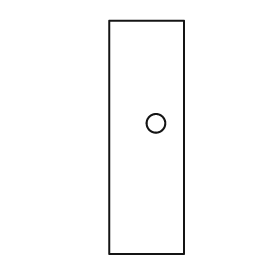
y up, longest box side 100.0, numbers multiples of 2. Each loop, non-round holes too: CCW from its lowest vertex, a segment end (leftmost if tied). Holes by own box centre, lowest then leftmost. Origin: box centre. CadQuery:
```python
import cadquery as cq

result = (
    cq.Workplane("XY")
    .moveTo(-16.0, -50.0)
    .lineTo(16.0, -50.0)
    .lineTo(16.0, 50.0)
    .lineTo(-16.0, 50.0)
    .close()
    .moveTo(4.0, 6.0)
    .circle(4.0)
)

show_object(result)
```